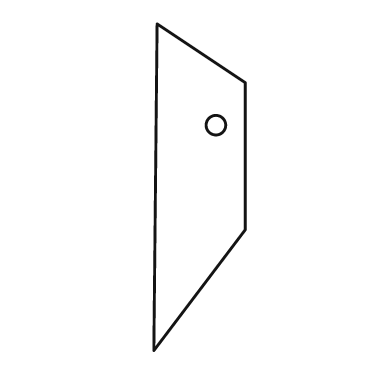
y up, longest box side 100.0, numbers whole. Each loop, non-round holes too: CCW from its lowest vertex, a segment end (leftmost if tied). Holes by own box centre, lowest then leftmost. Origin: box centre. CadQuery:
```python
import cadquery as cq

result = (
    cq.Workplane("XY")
    .moveTo(-14.0, -50.0)
    .lineTo(14.0, -13.0)
    .lineTo(14.0, 32.0)
    .lineTo(-13.0, 50.0)
    .close()
    .moveTo(5.0, 19.0)
    .circle(3.0)
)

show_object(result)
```